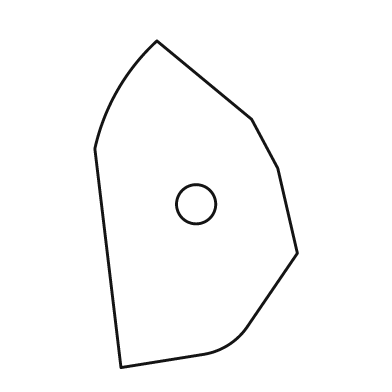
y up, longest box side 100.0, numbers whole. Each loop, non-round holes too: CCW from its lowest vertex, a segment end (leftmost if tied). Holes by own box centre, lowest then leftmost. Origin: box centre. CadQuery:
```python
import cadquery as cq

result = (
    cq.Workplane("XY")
    .moveTo(-23.0, -50.0)
    .lineTo(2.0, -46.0)
    .threePointArc((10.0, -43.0), (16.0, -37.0))
    .lineTo(31.0, -15.0)
    .lineTo(25.0, 11.0)
    .lineTo(17.0, 26.0)
    .lineTo(-12.0, 50.0)
    .threePointArc((-24.0, 35.0), (-31.0, 17.0))
    .close()
    .moveTo(0.0, 0.0)
    .circle(6.0)
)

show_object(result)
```